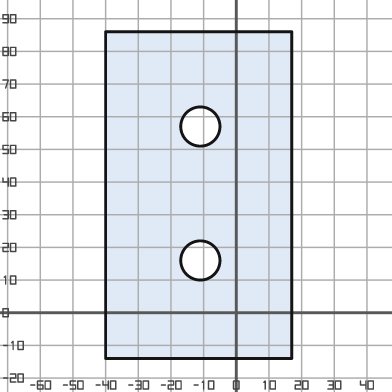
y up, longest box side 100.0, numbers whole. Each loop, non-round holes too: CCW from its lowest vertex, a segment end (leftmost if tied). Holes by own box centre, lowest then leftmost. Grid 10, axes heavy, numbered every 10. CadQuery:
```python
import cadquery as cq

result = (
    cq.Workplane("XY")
    .moveTo(-40.0, -14.0)
    .lineTo(17.0, -14.0)
    .lineTo(17.0, 86.0)
    .lineTo(-40.0, 86.0)
    .close()
    .moveTo(-11.0, 16.0)
    .circle(6.0)
    .moveTo(-11.0, 57.0)
    .circle(6.0)
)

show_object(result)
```